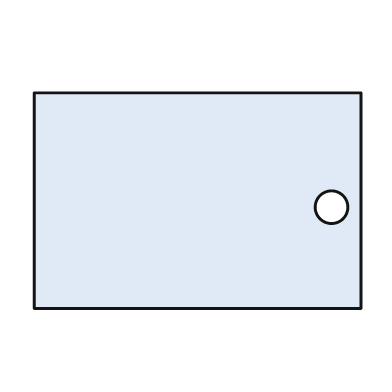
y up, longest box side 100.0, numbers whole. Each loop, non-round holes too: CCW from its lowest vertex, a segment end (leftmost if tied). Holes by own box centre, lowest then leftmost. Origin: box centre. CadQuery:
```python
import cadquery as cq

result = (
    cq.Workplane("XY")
    .moveTo(-50.0, -33.0)
    .lineTo(50.0, -33.0)
    .lineTo(50.0, 33.0)
    .lineTo(-50.0, 33.0)
    .close()
    .moveTo(41.0, -2.0)
    .circle(5.0)
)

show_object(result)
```